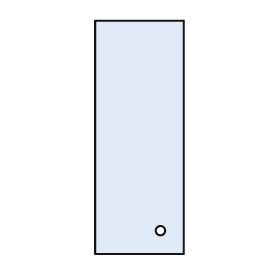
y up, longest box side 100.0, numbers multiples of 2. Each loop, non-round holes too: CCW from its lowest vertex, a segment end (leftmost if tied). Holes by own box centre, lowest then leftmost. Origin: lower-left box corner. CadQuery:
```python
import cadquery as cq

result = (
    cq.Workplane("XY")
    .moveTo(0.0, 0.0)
    .lineTo(38.0, 0.0)
    .lineTo(38.0, 100.0)
    .lineTo(0.0, 100.0)
    .close()
    .moveTo(28.0, 10.0)
    .circle(2.0)
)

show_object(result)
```